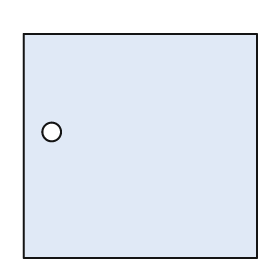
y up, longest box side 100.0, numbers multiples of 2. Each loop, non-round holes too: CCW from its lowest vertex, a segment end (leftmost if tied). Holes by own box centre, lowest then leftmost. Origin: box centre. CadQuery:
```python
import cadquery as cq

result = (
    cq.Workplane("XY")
    .moveTo(-50.0, -48.0)
    .lineTo(50.0, -48.0)
    .lineTo(50.0, 48.0)
    .lineTo(-50.0, 48.0)
    .close()
    .moveTo(-38.0, 6.0)
    .circle(4.0)
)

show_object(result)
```